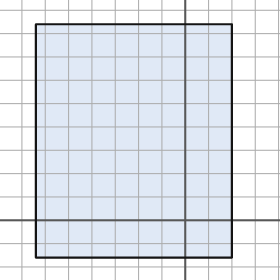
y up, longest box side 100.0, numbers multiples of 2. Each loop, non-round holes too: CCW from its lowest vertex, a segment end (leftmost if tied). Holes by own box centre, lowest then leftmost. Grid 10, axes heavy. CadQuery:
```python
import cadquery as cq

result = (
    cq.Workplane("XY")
    .moveTo(-64.0, -16.0)
    .lineTo(20.0, -16.0)
    .lineTo(20.0, 84.0)
    .lineTo(-64.0, 84.0)
    .close()
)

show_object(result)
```